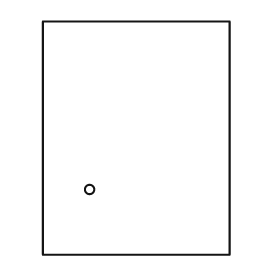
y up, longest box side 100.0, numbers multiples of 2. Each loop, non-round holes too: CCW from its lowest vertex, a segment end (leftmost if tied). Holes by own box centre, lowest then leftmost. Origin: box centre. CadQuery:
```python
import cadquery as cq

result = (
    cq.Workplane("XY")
    .moveTo(-40.0, -50.0)
    .lineTo(40.0, -50.0)
    .lineTo(40.0, 50.0)
    .lineTo(-40.0, 50.0)
    .close()
    .moveTo(-20.0, -22.0)
    .circle(2.0)
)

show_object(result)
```